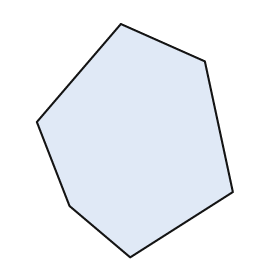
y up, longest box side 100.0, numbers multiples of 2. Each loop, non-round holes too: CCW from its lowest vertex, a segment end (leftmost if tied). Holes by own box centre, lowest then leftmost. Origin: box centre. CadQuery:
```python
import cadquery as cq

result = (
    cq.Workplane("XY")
    .moveTo(-2.0, -50.0)
    .lineTo(42.0, -22.0)
    .lineTo(30.0, 34.0)
    .lineTo(-6.0, 50.0)
    .lineTo(-42.0, 8.0)
    .lineTo(-28.0, -28.0)
    .close()
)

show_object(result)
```